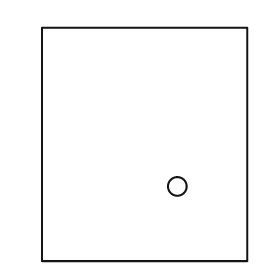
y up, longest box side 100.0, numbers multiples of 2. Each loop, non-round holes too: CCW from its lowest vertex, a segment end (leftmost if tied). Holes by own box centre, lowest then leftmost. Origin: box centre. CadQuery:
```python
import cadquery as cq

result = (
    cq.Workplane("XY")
    .moveTo(-44.0, -50.0)
    .lineTo(44.0, -50.0)
    .lineTo(44.0, 50.0)
    .lineTo(-44.0, 50.0)
    .close()
    .moveTo(14.0, -18.0)
    .circle(4.0)
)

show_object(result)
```